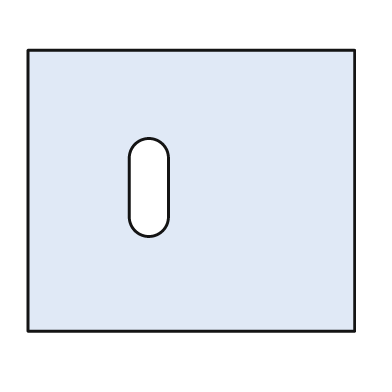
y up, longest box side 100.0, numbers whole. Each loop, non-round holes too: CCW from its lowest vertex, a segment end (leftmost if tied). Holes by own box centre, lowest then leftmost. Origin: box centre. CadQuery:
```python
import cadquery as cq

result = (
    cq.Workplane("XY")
    .moveTo(-50.0, -43.0)
    .lineTo(50.0, -43.0)
    .lineTo(50.0, 43.0)
    .lineTo(-50.0, 43.0)
    .close()
    .moveTo(-19.0, -8.0)
    .threePointArc((-13.0, -14.0), (-7.0, -8.0))
    .lineTo(-7.0, 10.0)
    .threePointArc((-13.0, 16.0), (-19.0, 10.0))
    .close()
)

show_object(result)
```